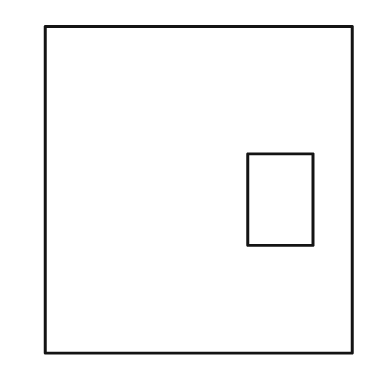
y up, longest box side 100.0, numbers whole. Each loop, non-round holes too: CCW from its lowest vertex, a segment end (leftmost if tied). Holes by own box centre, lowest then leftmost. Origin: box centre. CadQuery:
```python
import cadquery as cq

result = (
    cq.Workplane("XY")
    .moveTo(-47.0, -50.0)
    .lineTo(47.0, -50.0)
    .lineTo(47.0, 50.0)
    .lineTo(-47.0, 50.0)
    .close()
    .moveTo(15.0, -17.0)
    .lineTo(35.0, -17.0)
    .lineTo(35.0, 11.0)
    .lineTo(15.0, 11.0)
    .close()
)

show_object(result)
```